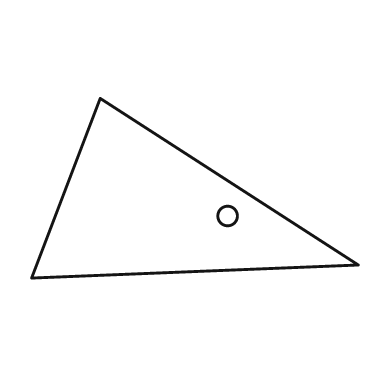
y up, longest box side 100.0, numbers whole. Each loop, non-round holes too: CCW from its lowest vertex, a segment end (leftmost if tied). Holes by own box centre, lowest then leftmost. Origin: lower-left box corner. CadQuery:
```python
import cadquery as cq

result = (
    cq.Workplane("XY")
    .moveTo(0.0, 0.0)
    .lineTo(100.0, 4.0)
    .lineTo(21.0, 55.0)
    .close()
    .moveTo(60.0, 19.0)
    .circle(3.0)
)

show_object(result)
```